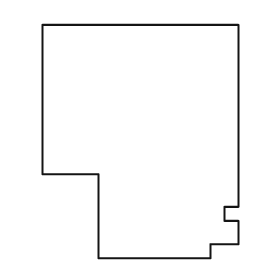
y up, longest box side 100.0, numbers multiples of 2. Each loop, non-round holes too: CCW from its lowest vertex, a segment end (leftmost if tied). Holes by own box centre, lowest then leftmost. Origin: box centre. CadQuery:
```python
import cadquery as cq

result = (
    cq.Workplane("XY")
    .moveTo(-18.0, -50.0)
    .lineTo(30.0, -50.0)
    .lineTo(30.0, -44.0)
    .lineTo(42.0, -44.0)
    .lineTo(42.0, -34.0)
    .lineTo(36.0, -34.0)
    .lineTo(36.0, -28.0)
    .lineTo(42.0, -28.0)
    .lineTo(42.0, 50.0)
    .lineTo(-42.0, 50.0)
    .lineTo(-42.0, -14.0)
    .lineTo(-18.0, -14.0)
    .close()
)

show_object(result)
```